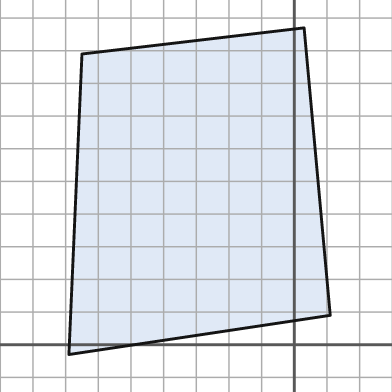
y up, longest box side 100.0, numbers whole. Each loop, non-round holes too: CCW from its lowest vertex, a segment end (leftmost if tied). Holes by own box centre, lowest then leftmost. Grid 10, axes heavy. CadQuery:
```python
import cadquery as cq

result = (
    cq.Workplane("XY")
    .moveTo(-69.0, -3.0)
    .lineTo(11.0, 9.0)
    .lineTo(3.0, 97.0)
    .lineTo(-65.0, 89.0)
    .close()
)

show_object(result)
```